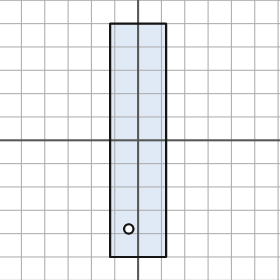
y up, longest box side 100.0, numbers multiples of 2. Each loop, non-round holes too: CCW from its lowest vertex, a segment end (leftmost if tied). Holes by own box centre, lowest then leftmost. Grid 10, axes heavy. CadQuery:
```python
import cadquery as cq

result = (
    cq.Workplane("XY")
    .moveTo(-12.0, -50.0)
    .lineTo(12.0, -50.0)
    .lineTo(12.0, 50.0)
    .lineTo(-12.0, 50.0)
    .close()
    .moveTo(-4.0, -38.0)
    .circle(2.0)
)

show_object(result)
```